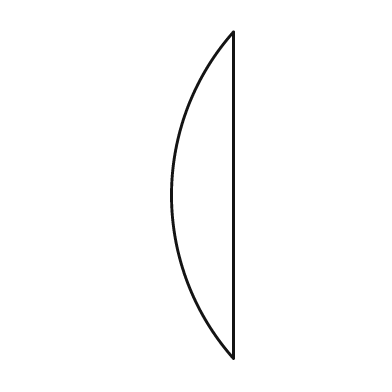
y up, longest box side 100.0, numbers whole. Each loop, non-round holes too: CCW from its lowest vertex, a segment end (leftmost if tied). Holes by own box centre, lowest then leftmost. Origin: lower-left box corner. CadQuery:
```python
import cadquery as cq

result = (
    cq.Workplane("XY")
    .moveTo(19.0, 0.0)
    .lineTo(19.0, 100.0)
    .threePointArc((0.0, 50.0), (19.0, 0.0))
    .close()
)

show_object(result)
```